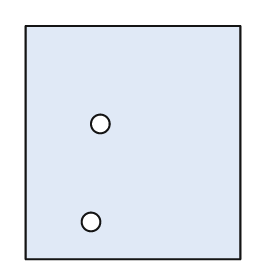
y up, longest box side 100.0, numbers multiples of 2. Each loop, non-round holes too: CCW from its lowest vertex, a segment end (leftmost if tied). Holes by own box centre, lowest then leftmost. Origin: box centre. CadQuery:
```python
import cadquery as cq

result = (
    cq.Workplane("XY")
    .moveTo(-46.0, -50.0)
    .lineTo(46.0, -50.0)
    .lineTo(46.0, 50.0)
    .lineTo(-46.0, 50.0)
    .close()
    .moveTo(-18.0, -34.0)
    .circle(4.0)
    .moveTo(-14.0, 8.0)
    .circle(4.0)
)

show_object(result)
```